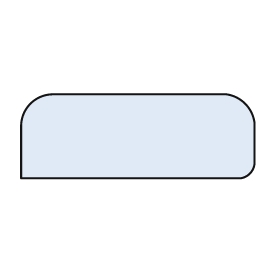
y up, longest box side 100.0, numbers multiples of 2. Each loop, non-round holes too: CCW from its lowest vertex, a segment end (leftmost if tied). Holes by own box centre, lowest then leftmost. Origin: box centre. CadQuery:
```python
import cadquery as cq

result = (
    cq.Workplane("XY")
    .moveTo(-50.0, -18.0)
    .lineTo(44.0, -18.0)
    .threePointArc((48.0, -16.0), (50.0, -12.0))
    .lineTo(50.0, 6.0)
    .threePointArc((46.0, 14.0), (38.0, 18.0))
    .lineTo(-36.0, 18.0)
    .threePointArc((-46.0, 14.0), (-50.0, 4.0))
    .close()
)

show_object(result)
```